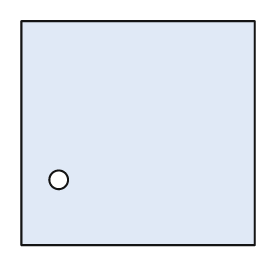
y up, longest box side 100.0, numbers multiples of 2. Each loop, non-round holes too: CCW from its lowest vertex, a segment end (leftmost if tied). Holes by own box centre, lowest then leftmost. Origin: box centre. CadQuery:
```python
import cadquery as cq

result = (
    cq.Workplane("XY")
    .moveTo(-50.0, -48.0)
    .lineTo(50.0, -48.0)
    .lineTo(50.0, 48.0)
    .lineTo(-50.0, 48.0)
    .close()
    .moveTo(-34.0, -20.0)
    .circle(4.0)
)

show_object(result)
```